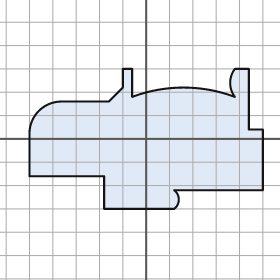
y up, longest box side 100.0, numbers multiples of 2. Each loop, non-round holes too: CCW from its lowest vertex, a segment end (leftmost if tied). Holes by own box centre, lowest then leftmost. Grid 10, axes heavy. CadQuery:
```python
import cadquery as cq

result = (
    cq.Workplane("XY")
    .moveTo(-18.0, -30.0)
    .lineTo(12.0, -30.0)
    .threePointArc((14.0, -26.0), (12.0, -22.0))
    .lineTo(50.0, -22.0)
    .lineTo(50.0, 4.0)
    .lineTo(44.0, 4.0)
    .lineTo(44.0, 30.0)
    .lineTo(38.0, 30.0)
    .threePointArc((36.0, 24.0), (38.0, 18.0))
    .threePointArc((16.0, 22.0), (-6.0, 18.0))
    .lineTo(-6.0, 30.0)
    .lineTo(-10.0, 30.0)
    .lineTo(-10.0, 22.0)
    .lineTo(-16.0, 16.0)
    .lineTo(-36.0, 16.0)
    .threePointArc((-46.0, 12.0), (-50.0, 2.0))
    .lineTo(-50.0, -16.0)
    .lineTo(-18.0, -16.0)
    .close()
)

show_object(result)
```